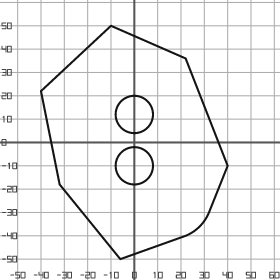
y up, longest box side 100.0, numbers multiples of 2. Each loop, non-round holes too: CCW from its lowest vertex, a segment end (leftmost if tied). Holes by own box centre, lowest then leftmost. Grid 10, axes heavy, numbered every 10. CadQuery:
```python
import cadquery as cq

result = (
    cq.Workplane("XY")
    .moveTo(-6.0, -50.0)
    .lineTo(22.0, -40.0)
    .threePointArc((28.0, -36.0), (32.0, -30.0))
    .lineTo(40.0, -10.0)
    .lineTo(22.0, 36.0)
    .lineTo(-10.0, 50.0)
    .lineTo(-40.0, 22.0)
    .lineTo(-32.0, -18.0)
    .close()
    .moveTo(0.0, -10.0)
    .circle(8.0)
    .moveTo(0.0, 12.0)
    .circle(8.0)
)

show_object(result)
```